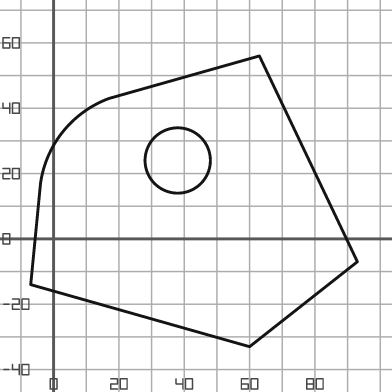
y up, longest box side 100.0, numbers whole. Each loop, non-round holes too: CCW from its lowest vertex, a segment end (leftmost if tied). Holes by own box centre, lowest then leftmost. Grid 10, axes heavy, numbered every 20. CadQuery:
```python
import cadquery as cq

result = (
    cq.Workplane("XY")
    .moveTo(60.0, -33.0)
    .lineTo(93.0, -7.0)
    .lineTo(63.0, 56.0)
    .lineTo(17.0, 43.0)
    .threePointArc((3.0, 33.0), (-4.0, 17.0))
    .lineTo(-7.0, -14.0)
    .close()
    .moveTo(38.0, 24.0)
    .circle(10.0)
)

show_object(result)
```